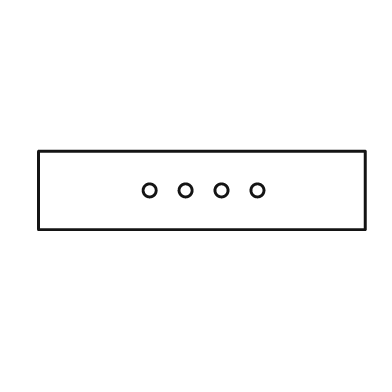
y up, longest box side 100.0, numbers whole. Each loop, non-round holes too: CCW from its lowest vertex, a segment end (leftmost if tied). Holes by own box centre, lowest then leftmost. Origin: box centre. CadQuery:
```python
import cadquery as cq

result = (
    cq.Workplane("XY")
    .moveTo(-50.0, -12.0)
    .lineTo(50.0, -12.0)
    .lineTo(50.0, 12.0)
    .lineTo(-50.0, 12.0)
    .close()
    .moveTo(-16.0, 0.0)
    .circle(2.0)
    .moveTo(-5.0, 0.0)
    .circle(2.0)
    .moveTo(6.0, 0.0)
    .circle(2.0)
    .moveTo(17.0, 0.0)
    .circle(2.0)
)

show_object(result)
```